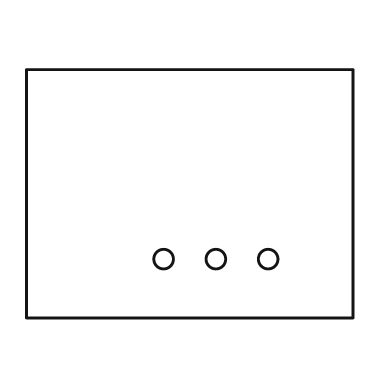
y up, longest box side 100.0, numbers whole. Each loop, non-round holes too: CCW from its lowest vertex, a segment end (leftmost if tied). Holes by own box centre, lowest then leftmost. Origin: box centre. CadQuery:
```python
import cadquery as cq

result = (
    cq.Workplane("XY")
    .moveTo(-50.0, -38.0)
    .lineTo(50.0, -38.0)
    .lineTo(50.0, 38.0)
    .lineTo(-50.0, 38.0)
    .close()
    .moveTo(-8.0, -20.0)
    .circle(3.0)
    .moveTo(8.0, -20.0)
    .circle(3.0)
    .moveTo(24.0, -20.0)
    .circle(3.0)
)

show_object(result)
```